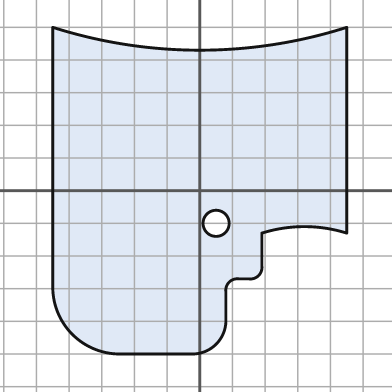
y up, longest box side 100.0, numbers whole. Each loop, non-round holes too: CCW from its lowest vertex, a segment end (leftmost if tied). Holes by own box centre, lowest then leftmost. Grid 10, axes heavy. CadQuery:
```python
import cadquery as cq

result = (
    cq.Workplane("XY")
    .moveTo(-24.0, -50.0)
    .lineTo(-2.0, -50.0)
    .threePointArc((5.0, -47.0), (8.0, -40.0))
    .lineTo(8.0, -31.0)
    .threePointArc((9.0, -28.0), (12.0, -27.0))
    .lineTo(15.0, -27.0)
    .threePointArc((18.0, -26.0), (19.0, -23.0))
    .lineTo(19.0, -13.0)
    .threePointArc((32.0, -11.0), (45.0, -13.0))
    .lineTo(45.0, 50.0)
    .threePointArc((0.0, 43.0), (-45.0, 50.0))
    .lineTo(-45.0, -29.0)
    .threePointArc((-39.0, -44.0), (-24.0, -50.0))
    .close()
    .moveTo(5.0, -10.0)
    .circle(4.0)
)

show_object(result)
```